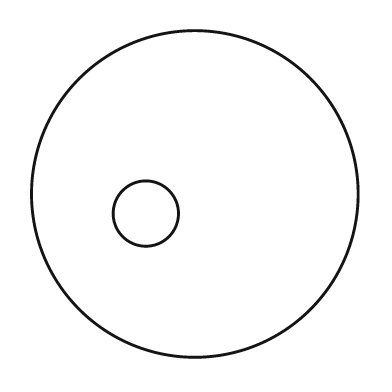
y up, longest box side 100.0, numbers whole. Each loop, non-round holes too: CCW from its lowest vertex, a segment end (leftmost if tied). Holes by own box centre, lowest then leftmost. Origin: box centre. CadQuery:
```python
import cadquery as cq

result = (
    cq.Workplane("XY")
    .moveTo(0.0, 0.0)
    .circle(50.0)
    .moveTo(-15.0, -6.0)
    .circle(10.0)
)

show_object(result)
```